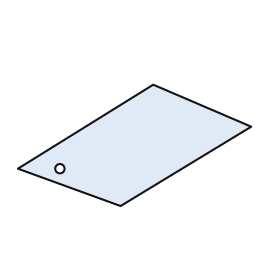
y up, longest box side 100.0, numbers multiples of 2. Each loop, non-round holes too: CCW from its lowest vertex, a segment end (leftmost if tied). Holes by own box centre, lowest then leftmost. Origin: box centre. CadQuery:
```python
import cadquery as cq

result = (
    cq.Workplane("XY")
    .moveTo(-6.0, -26.0)
    .lineTo(50.0, 8.0)
    .lineTo(8.0, 26.0)
    .lineTo(-50.0, -10.0)
    .close()
    .moveTo(-32.0, -10.0)
    .circle(2.0)
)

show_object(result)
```